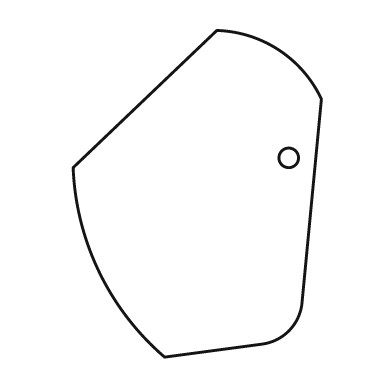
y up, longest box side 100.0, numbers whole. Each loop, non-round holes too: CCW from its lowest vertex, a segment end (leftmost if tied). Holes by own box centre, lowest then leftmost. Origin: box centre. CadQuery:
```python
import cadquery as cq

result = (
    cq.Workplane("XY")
    .moveTo(-10.0, -50.0)
    .lineTo(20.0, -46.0)
    .threePointArc((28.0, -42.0), (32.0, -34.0))
    .lineTo(38.0, 29.0)
    .threePointArc((25.0, 44.0), (6.0, 50.0))
    .lineTo(-38.0, 8.0)
    .threePointArc((-30.0, -24.0), (-10.0, -50.0))
    .close()
    .moveTo(28.0, 11.0)
    .circle(3.0)
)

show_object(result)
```